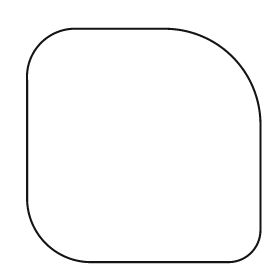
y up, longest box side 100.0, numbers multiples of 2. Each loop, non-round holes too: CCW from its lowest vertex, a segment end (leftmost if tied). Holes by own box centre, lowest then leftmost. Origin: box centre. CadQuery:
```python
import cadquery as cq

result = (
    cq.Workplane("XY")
    .moveTo(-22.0, -50.0)
    .lineTo(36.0, -50.0)
    .threePointArc((46.0, -46.0), (50.0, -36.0))
    .lineTo(50.0, 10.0)
    .threePointArc((38.0, 38.0), (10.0, 50.0))
    .lineTo(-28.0, 50.0)
    .threePointArc((-44.0, 44.0), (-50.0, 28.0))
    .lineTo(-50.0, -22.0)
    .threePointArc((-42.0, -42.0), (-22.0, -50.0))
    .close()
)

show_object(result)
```